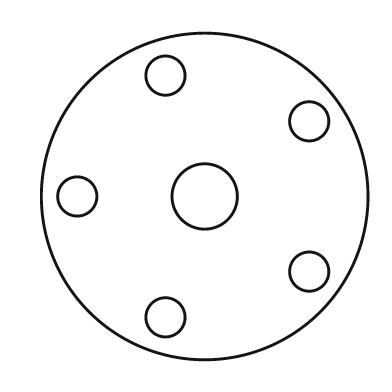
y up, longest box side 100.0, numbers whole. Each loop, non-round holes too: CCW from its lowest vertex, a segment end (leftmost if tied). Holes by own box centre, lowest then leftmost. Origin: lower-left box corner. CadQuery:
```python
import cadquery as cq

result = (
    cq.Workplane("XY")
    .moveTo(50.0, 50.0)
    .circle(50.0)
    .moveTo(38.0, 13.0)
    .circle(6.0)
    .moveTo(82.0, 27.0)
    .circle(6.0)
    .moveTo(11.0, 50.0)
    .circle(6.0)
    .moveTo(50.0, 50.0)
    .circle(10.0)
    .moveTo(82.0, 73.0)
    .circle(6.0)
    .moveTo(38.0, 87.0)
    .circle(6.0)
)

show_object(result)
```